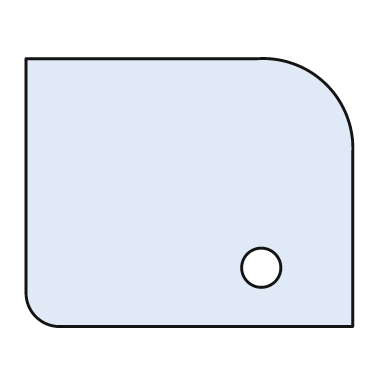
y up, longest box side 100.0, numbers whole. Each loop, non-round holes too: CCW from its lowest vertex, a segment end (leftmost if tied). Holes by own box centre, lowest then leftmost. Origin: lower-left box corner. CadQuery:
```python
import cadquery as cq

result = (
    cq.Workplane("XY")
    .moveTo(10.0, 0.0)
    .lineTo(100.0, 0.0)
    .lineTo(100.0, 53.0)
    .threePointArc((92.0, 74.0), (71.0, 82.0))
    .lineTo(0.0, 82.0)
    .lineTo(0.0, 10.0)
    .threePointArc((3.0, 3.0), (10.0, 0.0))
    .close()
    .moveTo(72.0, 18.0)
    .circle(6.0)
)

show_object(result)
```